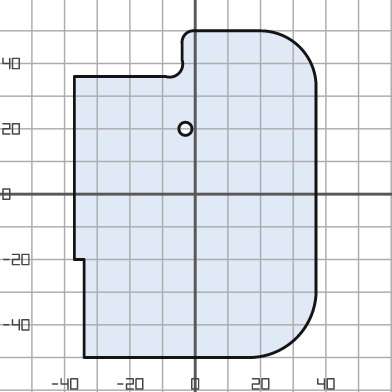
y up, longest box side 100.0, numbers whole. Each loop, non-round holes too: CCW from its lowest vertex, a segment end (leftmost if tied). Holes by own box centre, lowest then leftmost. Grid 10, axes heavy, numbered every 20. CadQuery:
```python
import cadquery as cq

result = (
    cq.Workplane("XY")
    .moveTo(-34.0, -50.0)
    .lineTo(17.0, -50.0)
    .threePointArc((31.0, -44.0), (37.0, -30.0))
    .lineTo(37.0, 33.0)
    .threePointArc((32.0, 45.0), (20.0, 50.0))
    .lineTo(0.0, 50.0)
    .threePointArc((-3.0, 49.0), (-4.0, 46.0))
    .lineTo(-4.0, 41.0)
    .threePointArc((-5.0, 37.0), (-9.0, 36.0))
    .lineTo(-37.0, 36.0)
    .lineTo(-37.0, -20.0)
    .lineTo(-34.0, -20.0)
    .close()
    .moveTo(-3.0, 20.0)
    .circle(2.0)
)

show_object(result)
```